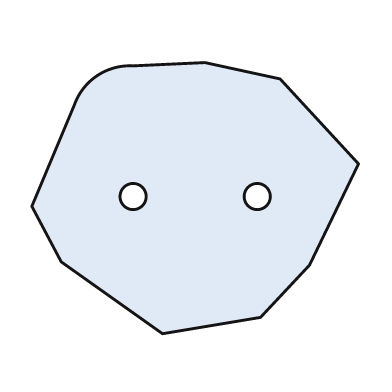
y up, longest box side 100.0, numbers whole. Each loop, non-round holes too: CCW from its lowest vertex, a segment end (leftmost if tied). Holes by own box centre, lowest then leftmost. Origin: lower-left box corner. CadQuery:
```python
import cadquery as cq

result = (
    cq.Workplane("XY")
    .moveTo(40.0, 0.0)
    .lineTo(70.0, 5.0)
    .lineTo(85.0, 21.0)
    .lineTo(100.0, 52.0)
    .lineTo(76.0, 78.0)
    .lineTo(53.0, 83.0)
    .lineTo(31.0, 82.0)
    .threePointArc((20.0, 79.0), (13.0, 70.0))
    .lineTo(0.0, 39.0)
    .lineTo(9.0, 22.0)
    .close()
    .moveTo(31.0, 42.0)
    .circle(4.0)
    .moveTo(69.0, 42.0)
    .circle(4.0)
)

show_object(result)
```